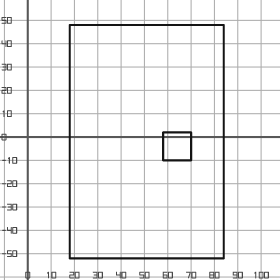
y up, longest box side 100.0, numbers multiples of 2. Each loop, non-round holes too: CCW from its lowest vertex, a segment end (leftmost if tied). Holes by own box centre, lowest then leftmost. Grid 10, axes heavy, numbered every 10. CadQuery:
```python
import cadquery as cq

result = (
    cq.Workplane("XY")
    .moveTo(18.0, -52.0)
    .lineTo(84.0, -52.0)
    .lineTo(84.0, 48.0)
    .lineTo(18.0, 48.0)
    .close()
    .moveTo(58.0, -10.0)
    .lineTo(70.0, -10.0)
    .lineTo(70.0, 2.0)
    .lineTo(58.0, 2.0)
    .close()
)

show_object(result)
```